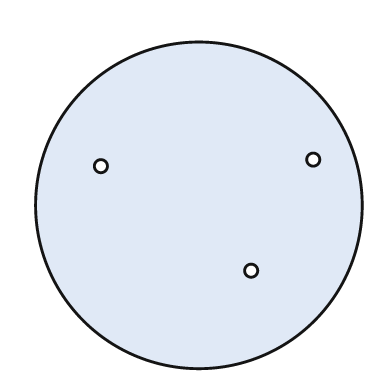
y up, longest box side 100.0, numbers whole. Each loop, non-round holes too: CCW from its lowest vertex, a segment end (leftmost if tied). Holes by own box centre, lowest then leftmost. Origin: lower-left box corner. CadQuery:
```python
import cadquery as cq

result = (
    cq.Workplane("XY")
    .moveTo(50.0, 50.0)
    .circle(50.0)
    .moveTo(66.0, 30.0)
    .circle(2.0)
    .moveTo(20.0, 62.0)
    .circle(2.0)
    .moveTo(85.0, 64.0)
    .circle(2.0)
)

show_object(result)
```